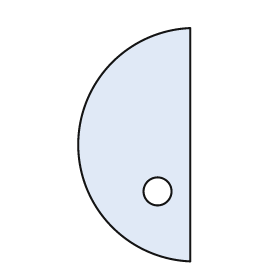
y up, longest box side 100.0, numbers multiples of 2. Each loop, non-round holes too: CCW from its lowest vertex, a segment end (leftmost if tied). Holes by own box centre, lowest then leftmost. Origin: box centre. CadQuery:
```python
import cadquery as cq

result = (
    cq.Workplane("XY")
    .moveTo(24.0, -50.0)
    .lineTo(24.0, 50.0)
    .threePointArc((-24.0, 0.0), (24.0, -50.0))
    .close()
    .moveTo(10.0, -20.0)
    .circle(6.0)
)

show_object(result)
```